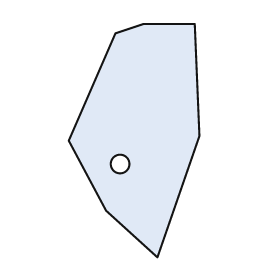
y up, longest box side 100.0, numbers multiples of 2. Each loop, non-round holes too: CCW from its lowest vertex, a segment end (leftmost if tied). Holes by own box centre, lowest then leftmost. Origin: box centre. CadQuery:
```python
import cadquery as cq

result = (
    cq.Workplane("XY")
    .moveTo(10.0, -50.0)
    .lineTo(28.0, 2.0)
    .lineTo(26.0, 50.0)
    .lineTo(4.0, 50.0)
    .lineTo(-8.0, 46.0)
    .lineTo(-28.0, 0.0)
    .lineTo(-12.0, -30.0)
    .close()
    .moveTo(-6.0, -10.0)
    .circle(4.0)
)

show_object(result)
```